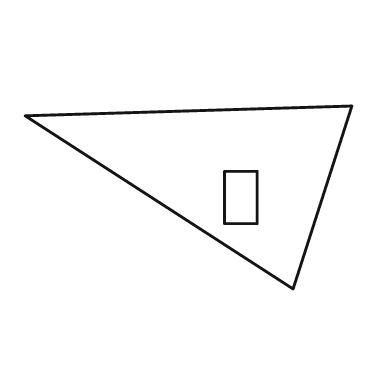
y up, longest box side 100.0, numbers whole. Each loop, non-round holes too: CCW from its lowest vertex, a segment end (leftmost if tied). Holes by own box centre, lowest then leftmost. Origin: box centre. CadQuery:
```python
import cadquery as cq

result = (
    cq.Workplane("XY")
    .moveTo(32.0, -28.0)
    .lineTo(50.0, 28.0)
    .lineTo(-50.0, 25.0)
    .close()
    .moveTo(11.0, -8.0)
    .lineTo(21.0, -8.0)
    .lineTo(21.0, 8.0)
    .lineTo(11.0, 8.0)
    .close()
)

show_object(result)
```